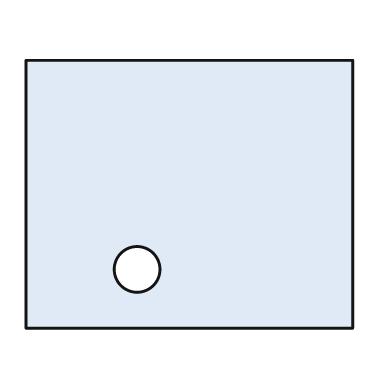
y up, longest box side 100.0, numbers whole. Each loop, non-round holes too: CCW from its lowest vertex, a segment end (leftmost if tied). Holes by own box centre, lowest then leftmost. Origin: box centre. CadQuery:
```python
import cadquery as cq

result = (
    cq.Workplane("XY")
    .moveTo(-50.0, -41.0)
    .lineTo(50.0, -41.0)
    .lineTo(50.0, 41.0)
    .lineTo(-50.0, 41.0)
    .close()
    .moveTo(-16.0, -23.0)
    .circle(7.0)
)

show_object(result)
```